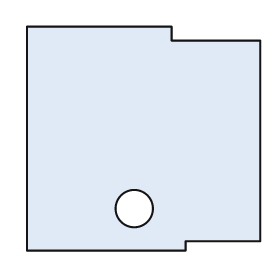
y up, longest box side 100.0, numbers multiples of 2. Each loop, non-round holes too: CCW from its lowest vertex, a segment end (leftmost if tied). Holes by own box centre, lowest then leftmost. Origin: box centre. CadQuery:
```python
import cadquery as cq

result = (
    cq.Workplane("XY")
    .moveTo(-50.0, -48.0)
    .lineTo(18.0, -48.0)
    .lineTo(18.0, -44.0)
    .lineTo(50.0, -44.0)
    .lineTo(50.0, 42.0)
    .lineTo(12.0, 42.0)
    .lineTo(12.0, 48.0)
    .lineTo(-50.0, 48.0)
    .close()
    .moveTo(-4.0, -30.0)
    .circle(8.0)
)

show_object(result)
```